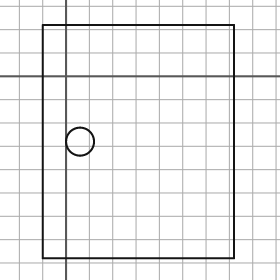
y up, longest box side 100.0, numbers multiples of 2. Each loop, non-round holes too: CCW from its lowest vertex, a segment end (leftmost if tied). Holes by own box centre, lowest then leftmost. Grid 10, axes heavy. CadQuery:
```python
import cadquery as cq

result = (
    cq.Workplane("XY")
    .moveTo(-10.0, -78.0)
    .lineTo(72.0, -78.0)
    .lineTo(72.0, 22.0)
    .lineTo(-10.0, 22.0)
    .close()
    .moveTo(6.0, -28.0)
    .circle(6.0)
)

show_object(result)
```